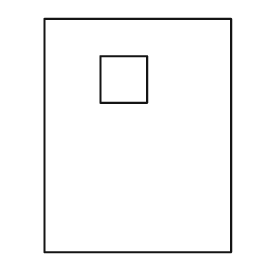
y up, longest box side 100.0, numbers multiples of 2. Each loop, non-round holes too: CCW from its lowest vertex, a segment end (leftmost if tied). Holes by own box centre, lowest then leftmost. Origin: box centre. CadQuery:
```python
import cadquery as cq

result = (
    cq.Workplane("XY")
    .moveTo(-40.0, -50.0)
    .lineTo(40.0, -50.0)
    .lineTo(40.0, 50.0)
    .lineTo(-40.0, 50.0)
    .close()
    .moveTo(-16.0, 14.0)
    .lineTo(4.0, 14.0)
    .lineTo(4.0, 34.0)
    .lineTo(-16.0, 34.0)
    .close()
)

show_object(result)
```